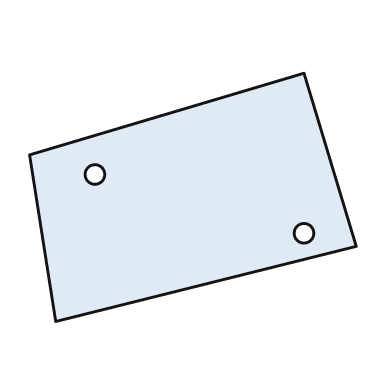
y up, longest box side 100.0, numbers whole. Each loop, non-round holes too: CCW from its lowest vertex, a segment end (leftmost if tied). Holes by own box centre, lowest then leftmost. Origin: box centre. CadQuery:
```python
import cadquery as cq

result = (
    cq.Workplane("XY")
    .moveTo(-42.0, -38.0)
    .lineTo(50.0, -15.0)
    .lineTo(34.0, 38.0)
    .lineTo(-50.0, 13.0)
    .close()
    .moveTo(34.0, -11.0)
    .circle(3.0)
    .moveTo(-30.0, 7.0)
    .circle(3.0)
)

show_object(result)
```